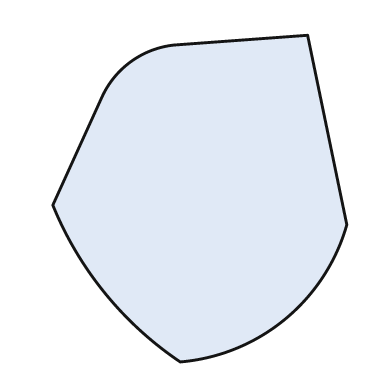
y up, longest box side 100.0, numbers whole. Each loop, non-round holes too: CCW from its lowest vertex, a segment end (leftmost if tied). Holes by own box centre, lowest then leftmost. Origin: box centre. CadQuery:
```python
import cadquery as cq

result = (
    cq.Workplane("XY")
    .moveTo(-6.0, -50.0)
    .threePointArc((26.0, -37.0), (45.0, -8.0))
    .lineTo(33.0, 50.0)
    .lineTo(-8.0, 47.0)
    .threePointArc((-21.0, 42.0), (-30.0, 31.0))
    .lineTo(-45.0, -2.0)
    .threePointArc((-29.0, -29.0), (-6.0, -50.0))
    .close()
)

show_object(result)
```